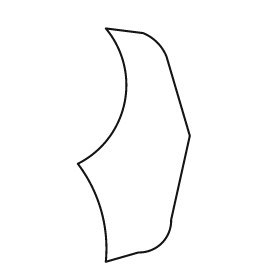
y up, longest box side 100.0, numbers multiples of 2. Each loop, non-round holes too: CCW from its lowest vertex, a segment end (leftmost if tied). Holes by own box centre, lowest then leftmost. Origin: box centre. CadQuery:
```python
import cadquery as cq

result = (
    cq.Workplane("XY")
    .moveTo(-12.0, -50.0)
    .lineTo(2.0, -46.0)
    .threePointArc((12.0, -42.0), (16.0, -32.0))
    .lineTo(24.0, 4.0)
    .lineTo(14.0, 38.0)
    .threePointArc((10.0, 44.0), (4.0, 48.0))
    .lineTo(-12.0, 50.0)
    .threePointArc((-4.0, 18.0), (-24.0, -8.0))
    .threePointArc((-14.0, -28.0), (-12.0, -50.0))
    .close()
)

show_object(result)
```